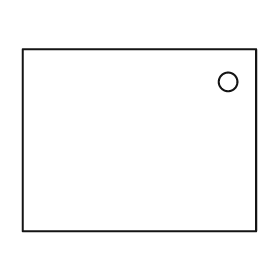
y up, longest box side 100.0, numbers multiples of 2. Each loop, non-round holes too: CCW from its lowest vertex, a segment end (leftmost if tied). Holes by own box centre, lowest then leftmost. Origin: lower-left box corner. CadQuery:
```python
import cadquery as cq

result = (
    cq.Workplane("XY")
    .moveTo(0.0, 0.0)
    .lineTo(100.0, 0.0)
    .lineTo(100.0, 78.0)
    .lineTo(0.0, 78.0)
    .close()
    .moveTo(88.0, 64.0)
    .circle(4.0)
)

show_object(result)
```